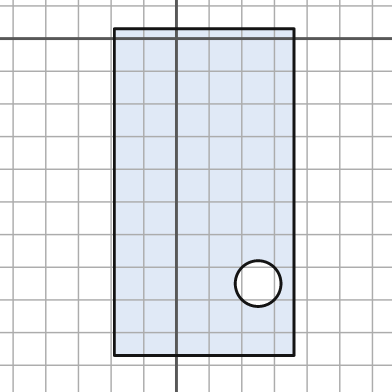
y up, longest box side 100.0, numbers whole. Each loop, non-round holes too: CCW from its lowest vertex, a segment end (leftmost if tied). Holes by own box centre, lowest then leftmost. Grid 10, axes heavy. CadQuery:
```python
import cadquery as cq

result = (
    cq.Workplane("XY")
    .moveTo(-19.0, -97.0)
    .lineTo(36.0, -97.0)
    .lineTo(36.0, 3.0)
    .lineTo(-19.0, 3.0)
    .close()
    .moveTo(25.0, -75.0)
    .circle(7.0)
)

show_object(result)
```